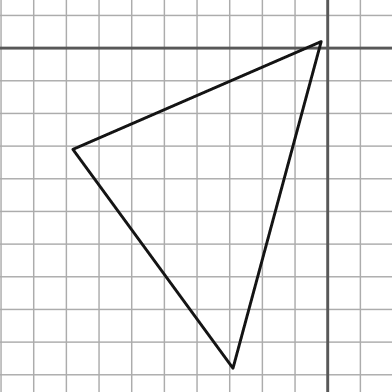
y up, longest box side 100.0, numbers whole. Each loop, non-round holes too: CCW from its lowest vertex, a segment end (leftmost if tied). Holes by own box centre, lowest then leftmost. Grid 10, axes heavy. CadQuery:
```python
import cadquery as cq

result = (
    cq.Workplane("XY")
    .moveTo(-29.0, -98.0)
    .lineTo(-2.0, 2.0)
    .lineTo(-78.0, -31.0)
    .close()
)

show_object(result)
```